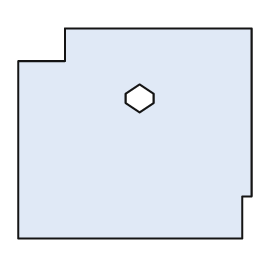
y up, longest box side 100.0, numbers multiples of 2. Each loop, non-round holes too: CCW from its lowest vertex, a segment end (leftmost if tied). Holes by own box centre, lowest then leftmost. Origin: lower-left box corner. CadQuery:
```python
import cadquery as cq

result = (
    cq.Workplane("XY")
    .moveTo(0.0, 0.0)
    .lineTo(96.0, 0.0)
    .lineTo(96.0, 18.0)
    .lineTo(100.0, 18.0)
    .lineTo(100.0, 90.0)
    .lineTo(20.0, 90.0)
    .lineTo(20.0, 76.0)
    .lineTo(0.0, 76.0)
    .close()
    .moveTo(52.0, 54.0)
    .lineTo(58.0, 58.0)
    .lineTo(58.0, 62.0)
    .lineTo(52.0, 66.0)
    .lineTo(46.0, 62.0)
    .lineTo(46.0, 58.0)
    .close()
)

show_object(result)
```